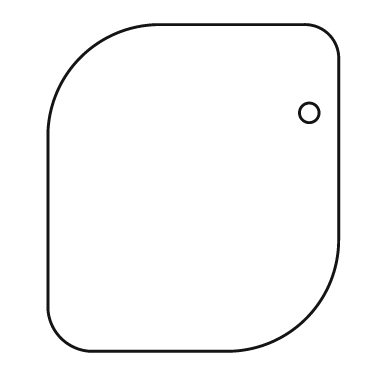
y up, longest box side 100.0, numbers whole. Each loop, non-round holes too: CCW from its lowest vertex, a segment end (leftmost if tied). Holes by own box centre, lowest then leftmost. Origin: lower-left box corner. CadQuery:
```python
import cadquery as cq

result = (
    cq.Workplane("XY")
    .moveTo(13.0, 0.0)
    .lineTo(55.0, 0.0)
    .threePointArc((79.0, 10.0), (89.0, 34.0))
    .lineTo(89.0, 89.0)
    .threePointArc((86.0, 97.0), (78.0, 100.0))
    .lineTo(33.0, 100.0)
    .threePointArc((10.0, 90.0), (0.0, 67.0))
    .lineTo(0.0, 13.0)
    .threePointArc((4.0, 4.0), (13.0, 0.0))
    .close()
    .moveTo(80.0, 73.0)
    .circle(3.0)
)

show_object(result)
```